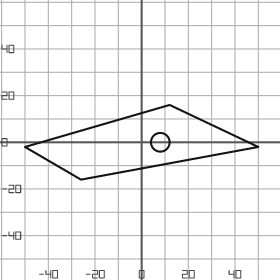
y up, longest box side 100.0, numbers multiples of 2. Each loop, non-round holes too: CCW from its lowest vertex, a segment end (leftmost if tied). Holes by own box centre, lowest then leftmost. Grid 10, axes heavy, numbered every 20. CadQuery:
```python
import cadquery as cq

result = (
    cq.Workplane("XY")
    .moveTo(-26.0, -16.0)
    .lineTo(50.0, -2.0)
    .lineTo(12.0, 16.0)
    .lineTo(-50.0, -2.0)
    .close()
    .moveTo(8.0, 0.0)
    .circle(4.0)
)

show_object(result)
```